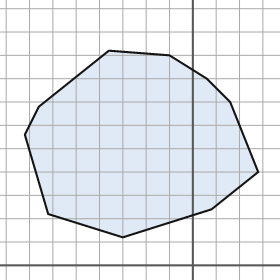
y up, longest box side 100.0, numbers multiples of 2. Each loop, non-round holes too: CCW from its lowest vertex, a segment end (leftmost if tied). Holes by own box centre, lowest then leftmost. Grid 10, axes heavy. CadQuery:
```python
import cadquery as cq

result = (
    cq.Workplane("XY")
    .moveTo(-30.0, 12.0)
    .lineTo(8.0, 24.0)
    .lineTo(28.0, 40.0)
    .lineTo(16.0, 70.0)
    .lineTo(6.0, 80.0)
    .lineTo(-10.0, 90.0)
    .lineTo(-36.0, 92.0)
    .lineTo(-66.0, 68.0)
    .lineTo(-72.0, 56.0)
    .lineTo(-62.0, 22.0)
    .close()
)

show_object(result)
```